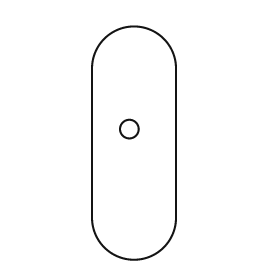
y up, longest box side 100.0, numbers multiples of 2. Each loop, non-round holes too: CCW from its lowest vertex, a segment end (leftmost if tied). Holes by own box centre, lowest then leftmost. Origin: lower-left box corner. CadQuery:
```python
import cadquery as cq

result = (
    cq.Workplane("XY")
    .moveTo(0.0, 18.0)
    .threePointArc((18.0, 0.0), (36.0, 18.0))
    .lineTo(36.0, 82.0)
    .threePointArc((18.0, 100.0), (0.0, 82.0))
    .close()
    .moveTo(16.0, 56.0)
    .circle(4.0)
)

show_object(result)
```